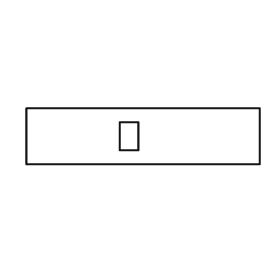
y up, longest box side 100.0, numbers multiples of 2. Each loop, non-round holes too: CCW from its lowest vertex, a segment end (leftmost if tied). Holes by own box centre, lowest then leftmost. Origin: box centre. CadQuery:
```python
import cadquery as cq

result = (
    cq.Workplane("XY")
    .moveTo(-50.0, -12.0)
    .lineTo(50.0, -12.0)
    .lineTo(50.0, 12.0)
    .lineTo(-50.0, 12.0)
    .close()
    .moveTo(-10.0, -6.0)
    .lineTo(-2.0, -6.0)
    .lineTo(-2.0, 6.0)
    .lineTo(-10.0, 6.0)
    .close()
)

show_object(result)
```